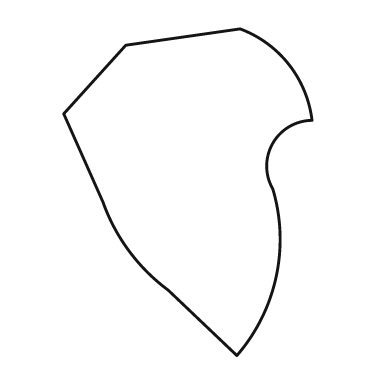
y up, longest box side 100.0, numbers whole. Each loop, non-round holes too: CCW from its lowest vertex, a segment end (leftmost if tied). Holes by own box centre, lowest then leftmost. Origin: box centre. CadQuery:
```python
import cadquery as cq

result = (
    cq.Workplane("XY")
    .moveTo(15.0, -50.0)
    .threePointArc((27.0, -26.0), (26.0, 1.0))
    .threePointArc((26.0, 15.0), (38.0, 22.0))
    .threePointArc((31.0, 39.0), (16.0, 50.0))
    .lineTo(-19.0, 45.0)
    .lineTo(-38.0, 24.0)
    .lineTo(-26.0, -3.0)
    .threePointArc((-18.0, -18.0), (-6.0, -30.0))
    .close()
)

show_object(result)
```